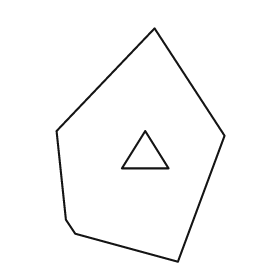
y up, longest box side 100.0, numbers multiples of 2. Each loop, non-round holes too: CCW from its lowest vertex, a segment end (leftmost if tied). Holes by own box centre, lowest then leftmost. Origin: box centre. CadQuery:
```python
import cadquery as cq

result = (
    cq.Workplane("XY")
    .moveTo(16.0, -50.0)
    .lineTo(36.0, 4.0)
    .lineTo(6.0, 50.0)
    .lineTo(-36.0, 6.0)
    .lineTo(-32.0, -32.0)
    .lineTo(-28.0, -38.0)
    .close()
    .moveTo(-8.0, -10.0)
    .lineTo(12.0, -10.0)
    .lineTo(2.0, 6.0)
    .close()
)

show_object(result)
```